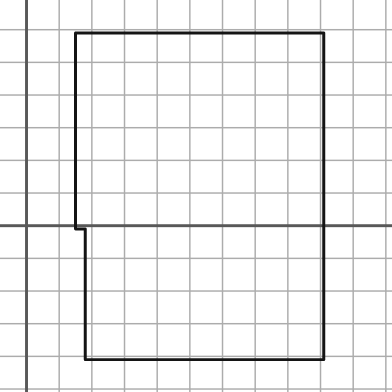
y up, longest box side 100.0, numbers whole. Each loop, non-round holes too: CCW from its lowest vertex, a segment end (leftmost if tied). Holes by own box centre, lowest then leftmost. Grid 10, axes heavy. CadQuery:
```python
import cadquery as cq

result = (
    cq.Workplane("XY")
    .moveTo(18.0, -41.0)
    .lineTo(91.0, -41.0)
    .lineTo(91.0, 59.0)
    .lineTo(15.0, 59.0)
    .lineTo(15.0, -1.0)
    .lineTo(18.0, -1.0)
    .close()
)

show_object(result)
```